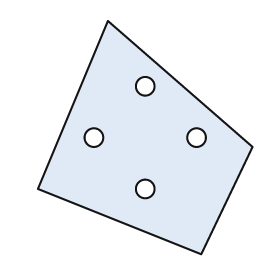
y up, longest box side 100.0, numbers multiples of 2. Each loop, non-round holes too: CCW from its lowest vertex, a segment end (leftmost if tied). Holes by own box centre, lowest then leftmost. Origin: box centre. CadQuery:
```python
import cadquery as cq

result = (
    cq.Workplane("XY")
    .moveTo(24.0, -50.0)
    .lineTo(46.0, -4.0)
    .lineTo(-16.0, 50.0)
    .lineTo(-46.0, -22.0)
    .close()
    .moveTo(0.0, -22.0)
    .circle(4.0)
    .moveTo(-22.0, 0.0)
    .circle(4.0)
    .moveTo(22.0, 0.0)
    .circle(4.0)
    .moveTo(0.0, 22.0)
    .circle(4.0)
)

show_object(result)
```